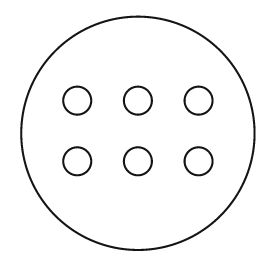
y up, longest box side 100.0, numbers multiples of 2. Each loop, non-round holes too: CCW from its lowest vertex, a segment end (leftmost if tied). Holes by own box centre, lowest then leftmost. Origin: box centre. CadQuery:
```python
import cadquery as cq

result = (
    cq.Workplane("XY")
    .moveTo(0.0, 0.0)
    .circle(50.0)
    .moveTo(-26.0, -12.0)
    .circle(6.0)
    .moveTo(0.0, -12.0)
    .circle(6.0)
    .moveTo(26.0, -12.0)
    .circle(6.0)
    .moveTo(-26.0, 14.0)
    .circle(6.0)
    .moveTo(0.0, 14.0)
    .circle(6.0)
    .moveTo(26.0, 14.0)
    .circle(6.0)
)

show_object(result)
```